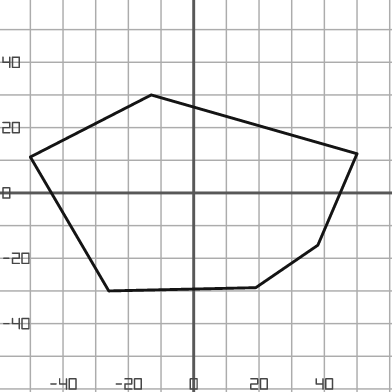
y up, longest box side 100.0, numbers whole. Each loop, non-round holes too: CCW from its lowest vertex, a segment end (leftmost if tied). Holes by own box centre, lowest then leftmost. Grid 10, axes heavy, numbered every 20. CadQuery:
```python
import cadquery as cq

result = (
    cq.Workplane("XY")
    .moveTo(-26.0, -30.0)
    .lineTo(19.0, -29.0)
    .lineTo(38.0, -16.0)
    .lineTo(50.0, 12.0)
    .lineTo(-13.0, 30.0)
    .lineTo(-50.0, 11.0)
    .close()
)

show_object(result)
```